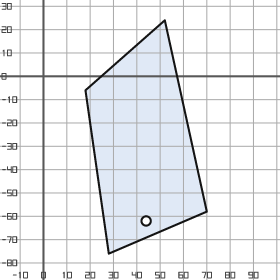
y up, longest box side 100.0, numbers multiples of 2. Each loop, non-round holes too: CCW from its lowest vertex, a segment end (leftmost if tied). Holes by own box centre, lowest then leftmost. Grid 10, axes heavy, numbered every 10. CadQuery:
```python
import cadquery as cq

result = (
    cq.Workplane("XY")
    .moveTo(28.0, -76.0)
    .lineTo(70.0, -58.0)
    .lineTo(52.0, 24.0)
    .lineTo(18.0, -6.0)
    .close()
    .moveTo(44.0, -62.0)
    .circle(2.0)
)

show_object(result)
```